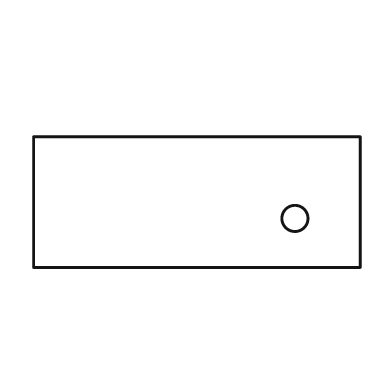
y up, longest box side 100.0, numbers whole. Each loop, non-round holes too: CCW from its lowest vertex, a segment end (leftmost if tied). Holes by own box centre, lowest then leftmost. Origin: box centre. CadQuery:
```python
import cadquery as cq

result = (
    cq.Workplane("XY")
    .moveTo(-50.0, -20.0)
    .lineTo(50.0, -20.0)
    .lineTo(50.0, 20.0)
    .lineTo(-50.0, 20.0)
    .close()
    .moveTo(30.0, -5.0)
    .circle(4.0)
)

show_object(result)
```